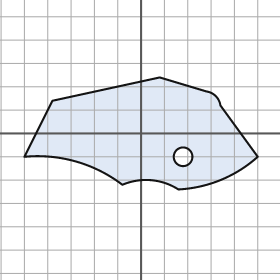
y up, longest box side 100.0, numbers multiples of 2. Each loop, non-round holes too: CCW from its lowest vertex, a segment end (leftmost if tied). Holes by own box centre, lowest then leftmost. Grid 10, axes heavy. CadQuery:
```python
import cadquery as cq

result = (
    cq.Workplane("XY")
    .moveTo(16.0, -24.0)
    .threePointArc((34.0, -20.0), (50.0, -10.0))
    .lineTo(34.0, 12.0)
    .threePointArc((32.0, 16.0), (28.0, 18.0))
    .lineTo(8.0, 24.0)
    .lineTo(-38.0, 14.0)
    .lineTo(-50.0, -10.0)
    .threePointArc((-28.0, -12.0), (-8.0, -22.0))
    .threePointArc((4.0, -20.0), (16.0, -24.0))
    .close()
    .moveTo(18.0, -10.0)
    .circle(4.0)
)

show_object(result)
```